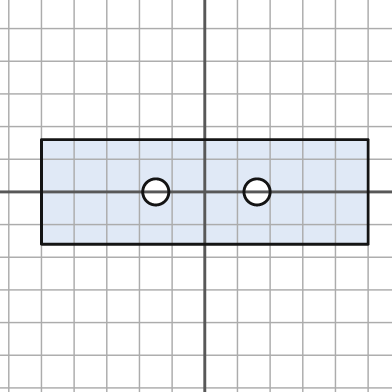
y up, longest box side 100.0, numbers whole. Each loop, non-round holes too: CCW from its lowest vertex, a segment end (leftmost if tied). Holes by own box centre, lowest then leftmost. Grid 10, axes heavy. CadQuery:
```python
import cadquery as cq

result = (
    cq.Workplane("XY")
    .moveTo(-50.0, -16.0)
    .lineTo(50.0, -16.0)
    .lineTo(50.0, 16.0)
    .lineTo(-50.0, 16.0)
    .close()
    .moveTo(-15.0, 0.0)
    .circle(4.0)
    .moveTo(16.0, 0.0)
    .circle(4.0)
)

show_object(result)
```